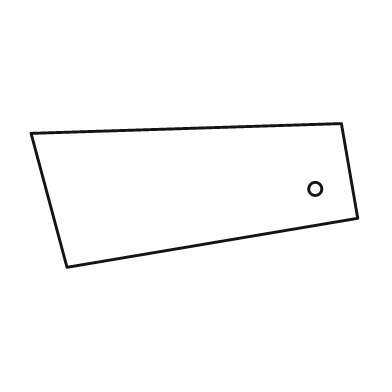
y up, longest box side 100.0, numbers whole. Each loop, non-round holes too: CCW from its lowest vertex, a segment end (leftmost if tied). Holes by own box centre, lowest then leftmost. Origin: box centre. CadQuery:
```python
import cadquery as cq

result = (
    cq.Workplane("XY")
    .moveTo(-39.0, -22.0)
    .lineTo(50.0, -7.0)
    .lineTo(45.0, 22.0)
    .lineTo(-50.0, 19.0)
    .close()
    .moveTo(37.0, 2.0)
    .circle(2.0)
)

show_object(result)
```